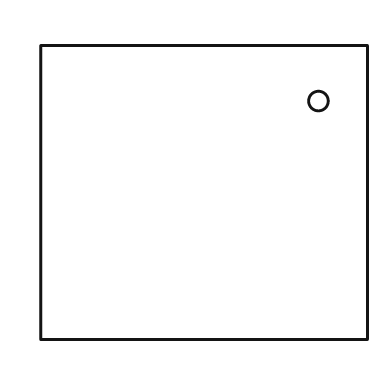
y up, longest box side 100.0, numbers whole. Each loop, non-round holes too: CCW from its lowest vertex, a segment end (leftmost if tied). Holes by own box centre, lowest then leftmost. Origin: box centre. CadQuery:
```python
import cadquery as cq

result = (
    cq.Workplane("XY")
    .moveTo(-50.0, -45.0)
    .lineTo(50.0, -45.0)
    .lineTo(50.0, 45.0)
    .lineTo(-50.0, 45.0)
    .close()
    .moveTo(35.0, 28.0)
    .circle(3.0)
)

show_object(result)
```